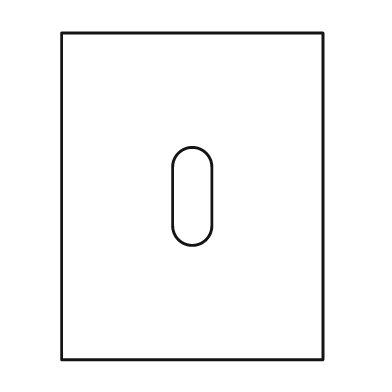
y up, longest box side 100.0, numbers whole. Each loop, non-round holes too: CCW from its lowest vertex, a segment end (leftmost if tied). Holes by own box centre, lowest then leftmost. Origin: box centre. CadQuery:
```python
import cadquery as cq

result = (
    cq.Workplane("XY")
    .moveTo(-40.0, -50.0)
    .lineTo(40.0, -50.0)
    .lineTo(40.0, 50.0)
    .lineTo(-40.0, 50.0)
    .close()
    .moveTo(-6.0, -9.0)
    .threePointArc((0.0, -15.0), (6.0, -9.0))
    .lineTo(6.0, 9.0)
    .threePointArc((0.0, 15.0), (-6.0, 9.0))
    .close()
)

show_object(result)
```